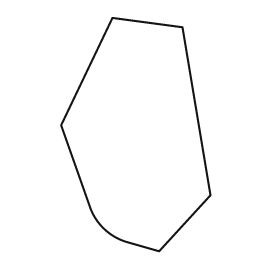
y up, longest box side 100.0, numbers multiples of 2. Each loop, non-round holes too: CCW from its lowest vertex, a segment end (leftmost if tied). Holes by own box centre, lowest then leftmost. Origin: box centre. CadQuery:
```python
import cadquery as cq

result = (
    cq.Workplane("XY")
    .moveTo(10.0, -50.0)
    .lineTo(32.0, -26.0)
    .lineTo(20.0, 46.0)
    .lineTo(-10.0, 50.0)
    .lineTo(-32.0, 4.0)
    .lineTo(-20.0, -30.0)
    .threePointArc((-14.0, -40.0), (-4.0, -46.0))
    .close()
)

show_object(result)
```